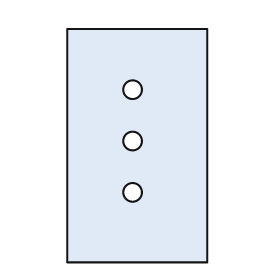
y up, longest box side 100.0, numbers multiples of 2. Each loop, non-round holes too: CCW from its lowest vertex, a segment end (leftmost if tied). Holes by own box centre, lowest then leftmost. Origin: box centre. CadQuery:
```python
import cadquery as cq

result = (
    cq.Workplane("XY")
    .moveTo(-30.0, -50.0)
    .lineTo(30.0, -50.0)
    .lineTo(30.0, 50.0)
    .lineTo(-30.0, 50.0)
    .close()
    .moveTo(-2.0, -20.0)
    .circle(4.0)
    .moveTo(-2.0, 2.0)
    .circle(4.0)
    .moveTo(-2.0, 24.0)
    .circle(4.0)
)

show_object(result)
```